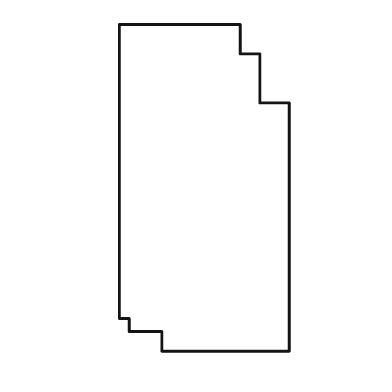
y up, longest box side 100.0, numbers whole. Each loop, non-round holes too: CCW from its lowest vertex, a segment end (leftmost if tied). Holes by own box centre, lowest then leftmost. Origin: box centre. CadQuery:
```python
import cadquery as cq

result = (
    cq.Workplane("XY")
    .moveTo(-13.0, -50.0)
    .lineTo(26.0, -50.0)
    .lineTo(26.0, 26.0)
    .lineTo(17.0, 26.0)
    .lineTo(17.0, 41.0)
    .lineTo(11.0, 41.0)
    .lineTo(11.0, 50.0)
    .lineTo(-26.0, 50.0)
    .lineTo(-26.0, -40.0)
    .lineTo(-23.0, -40.0)
    .lineTo(-23.0, -44.0)
    .lineTo(-13.0, -44.0)
    .close()
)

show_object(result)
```